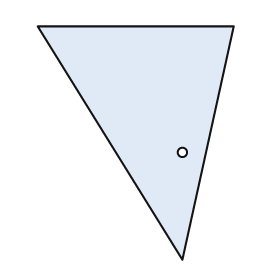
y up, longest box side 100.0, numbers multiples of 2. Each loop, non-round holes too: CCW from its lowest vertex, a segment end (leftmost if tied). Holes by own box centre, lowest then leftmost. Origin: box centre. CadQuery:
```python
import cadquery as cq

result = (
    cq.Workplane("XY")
    .moveTo(20.0, -50.0)
    .lineTo(42.0, 50.0)
    .lineTo(-42.0, 50.0)
    .close()
    .moveTo(20.0, -4.0)
    .circle(2.0)
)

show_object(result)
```